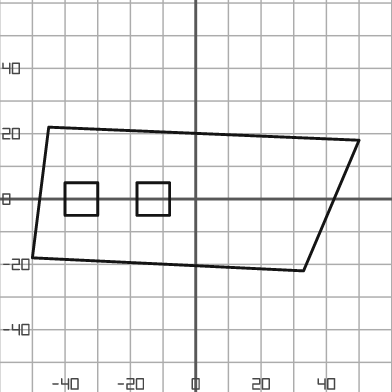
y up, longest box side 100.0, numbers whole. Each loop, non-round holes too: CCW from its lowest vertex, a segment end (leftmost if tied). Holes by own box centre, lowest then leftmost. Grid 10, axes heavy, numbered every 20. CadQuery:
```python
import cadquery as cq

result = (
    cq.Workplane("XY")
    .moveTo(33.0, -22.0)
    .lineTo(50.0, 18.0)
    .lineTo(-45.0, 22.0)
    .lineTo(-50.0, -18.0)
    .close()
    .moveTo(-40.0, -5.0)
    .lineTo(-30.0, -5.0)
    .lineTo(-30.0, 5.0)
    .lineTo(-40.0, 5.0)
    .close()
    .moveTo(-18.0, -5.0)
    .lineTo(-8.0, -5.0)
    .lineTo(-8.0, 5.0)
    .lineTo(-18.0, 5.0)
    .close()
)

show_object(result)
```